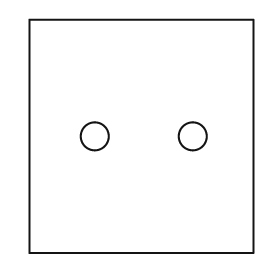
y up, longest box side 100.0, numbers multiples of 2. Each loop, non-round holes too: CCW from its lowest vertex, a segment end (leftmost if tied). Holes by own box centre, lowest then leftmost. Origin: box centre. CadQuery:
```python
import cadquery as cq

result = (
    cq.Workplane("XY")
    .moveTo(-48.0, -50.0)
    .lineTo(48.0, -50.0)
    .lineTo(48.0, 50.0)
    .lineTo(-48.0, 50.0)
    .close()
    .moveTo(-20.0, 0.0)
    .circle(6.0)
    .moveTo(22.0, 0.0)
    .circle(6.0)
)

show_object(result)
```